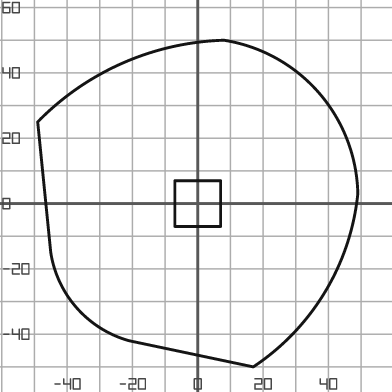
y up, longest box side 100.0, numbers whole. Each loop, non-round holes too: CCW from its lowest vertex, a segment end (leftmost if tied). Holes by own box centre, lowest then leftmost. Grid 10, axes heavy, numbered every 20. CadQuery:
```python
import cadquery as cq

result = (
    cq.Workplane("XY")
    .moveTo(17.0, -50.0)
    .threePointArc((39.0, -27.0), (49.0, 3.0))
    .threePointArc((37.0, 34.0), (8.0, 50.0))
    .threePointArc((-23.0, 43.0), (-49.0, 25.0))
    .lineTo(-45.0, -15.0)
    .threePointArc((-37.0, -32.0), (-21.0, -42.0))
    .close()
    .moveTo(-7.0, -7.0)
    .lineTo(7.0, -7.0)
    .lineTo(7.0, 7.0)
    .lineTo(-7.0, 7.0)
    .close()
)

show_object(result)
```